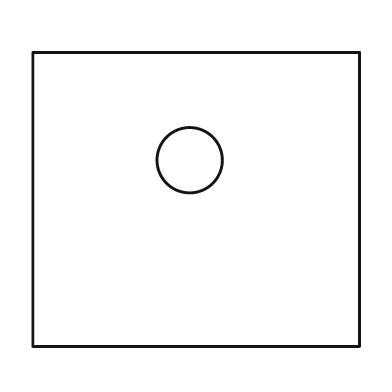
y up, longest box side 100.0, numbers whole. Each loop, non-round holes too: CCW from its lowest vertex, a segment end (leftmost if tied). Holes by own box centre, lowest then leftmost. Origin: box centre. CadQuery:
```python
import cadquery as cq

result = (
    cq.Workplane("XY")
    .moveTo(-50.0, -45.0)
    .lineTo(50.0, -45.0)
    .lineTo(50.0, 45.0)
    .lineTo(-50.0, 45.0)
    .close()
    .moveTo(-2.0, 12.0)
    .circle(10.0)
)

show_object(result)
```